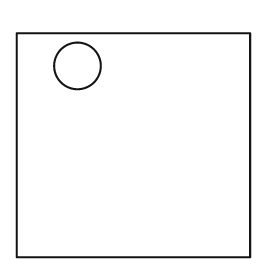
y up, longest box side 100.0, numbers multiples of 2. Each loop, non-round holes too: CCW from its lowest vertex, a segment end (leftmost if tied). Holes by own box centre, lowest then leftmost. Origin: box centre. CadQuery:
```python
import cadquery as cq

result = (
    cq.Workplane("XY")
    .moveTo(-50.0, -48.0)
    .lineTo(50.0, -48.0)
    .lineTo(50.0, 48.0)
    .lineTo(-50.0, 48.0)
    .close()
    .moveTo(-24.0, 34.0)
    .circle(10.0)
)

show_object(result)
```